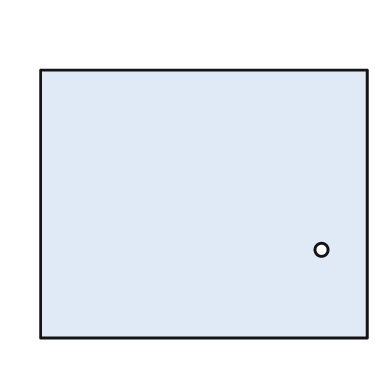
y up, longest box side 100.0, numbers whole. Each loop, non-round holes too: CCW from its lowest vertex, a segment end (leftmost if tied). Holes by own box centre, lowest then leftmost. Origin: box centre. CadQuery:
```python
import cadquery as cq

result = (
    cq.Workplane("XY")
    .moveTo(-50.0, -41.0)
    .lineTo(50.0, -41.0)
    .lineTo(50.0, 41.0)
    .lineTo(-50.0, 41.0)
    .close()
    .moveTo(36.0, -14.0)
    .circle(2.0)
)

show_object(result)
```